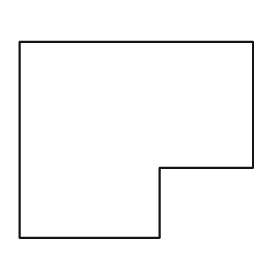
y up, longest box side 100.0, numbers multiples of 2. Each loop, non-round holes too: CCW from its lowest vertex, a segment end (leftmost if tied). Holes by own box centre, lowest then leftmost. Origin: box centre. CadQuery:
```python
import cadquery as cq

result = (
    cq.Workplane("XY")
    .moveTo(-50.0, -42.0)
    .lineTo(10.0, -42.0)
    .lineTo(10.0, -12.0)
    .lineTo(50.0, -12.0)
    .lineTo(50.0, 42.0)
    .lineTo(-50.0, 42.0)
    .close()
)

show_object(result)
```